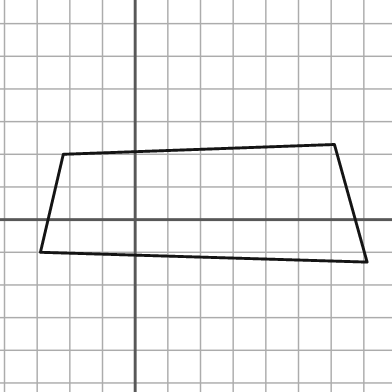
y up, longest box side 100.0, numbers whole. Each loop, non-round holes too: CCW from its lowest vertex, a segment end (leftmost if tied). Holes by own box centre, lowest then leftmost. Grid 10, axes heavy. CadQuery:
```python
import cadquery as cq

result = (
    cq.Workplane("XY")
    .moveTo(71.0, -13.0)
    .lineTo(61.0, 23.0)
    .lineTo(-22.0, 20.0)
    .lineTo(-29.0, -10.0)
    .close()
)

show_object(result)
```